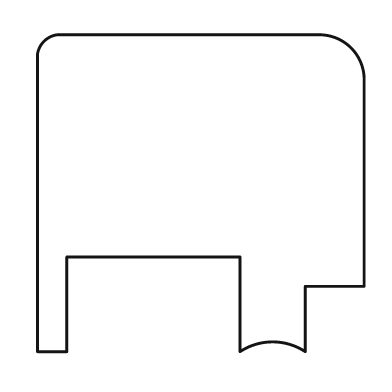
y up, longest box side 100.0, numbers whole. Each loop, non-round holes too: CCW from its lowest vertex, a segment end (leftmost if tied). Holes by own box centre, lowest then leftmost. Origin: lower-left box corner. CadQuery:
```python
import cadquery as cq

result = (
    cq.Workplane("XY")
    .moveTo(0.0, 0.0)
    .lineTo(9.0, 0.0)
    .lineTo(9.0, 29.0)
    .lineTo(62.0, 29.0)
    .lineTo(62.0, 0.0)
    .threePointArc((72.0, 3.0), (82.0, 0.0))
    .lineTo(82.0, 20.0)
    .lineTo(100.0, 20.0)
    .lineTo(100.0, 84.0)
    .threePointArc((96.0, 93.0), (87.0, 97.0))
    .lineTo(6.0, 97.0)
    .threePointArc((2.0, 95.0), (0.0, 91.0))
    .close()
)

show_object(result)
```